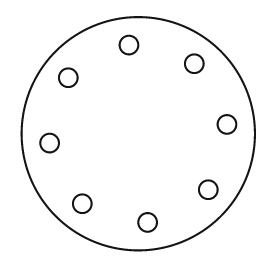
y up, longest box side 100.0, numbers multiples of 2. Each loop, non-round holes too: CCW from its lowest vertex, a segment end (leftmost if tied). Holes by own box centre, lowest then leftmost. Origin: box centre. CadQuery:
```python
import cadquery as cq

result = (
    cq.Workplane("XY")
    .moveTo(0.0, 0.0)
    .circle(50.0)
    .moveTo(4.0, -38.0)
    .circle(4.0)
    .moveTo(-24.0, -30.0)
    .circle(4.0)
    .moveTo(30.0, -24.0)
    .circle(4.0)
    .moveTo(-38.0, -4.0)
    .circle(4.0)
    .moveTo(38.0, 4.0)
    .circle(4.0)
    .moveTo(-30.0, 24.0)
    .circle(4.0)
    .moveTo(24.0, 30.0)
    .circle(4.0)
    .moveTo(-4.0, 38.0)
    .circle(4.0)
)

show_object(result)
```